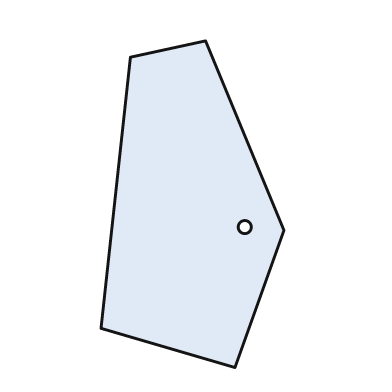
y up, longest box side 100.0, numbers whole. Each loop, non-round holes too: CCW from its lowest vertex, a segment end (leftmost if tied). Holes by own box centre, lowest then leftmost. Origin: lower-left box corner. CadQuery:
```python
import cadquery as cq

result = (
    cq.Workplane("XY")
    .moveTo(41.0, 0.0)
    .lineTo(56.0, 42.0)
    .lineTo(32.0, 100.0)
    .lineTo(9.0, 95.0)
    .lineTo(0.0, 12.0)
    .close()
    .moveTo(44.0, 43.0)
    .circle(2.0)
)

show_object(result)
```